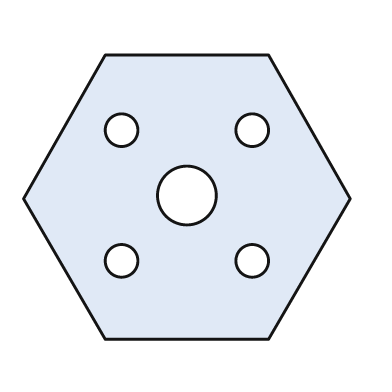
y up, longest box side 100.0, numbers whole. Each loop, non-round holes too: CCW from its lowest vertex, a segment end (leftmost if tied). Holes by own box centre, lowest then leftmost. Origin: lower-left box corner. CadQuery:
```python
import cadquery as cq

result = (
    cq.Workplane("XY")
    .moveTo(25.0, 0.0)
    .lineTo(75.0, 0.0)
    .lineTo(100.0, 43.0)
    .lineTo(75.0, 87.0)
    .lineTo(25.0, 87.0)
    .lineTo(0.0, 43.0)
    .close()
    .moveTo(30.0, 24.0)
    .circle(5.0)
    .moveTo(70.0, 24.0)
    .circle(5.0)
    .moveTo(50.0, 44.0)
    .circle(9.0)
    .moveTo(30.0, 64.0)
    .circle(5.0)
    .moveTo(70.0, 64.0)
    .circle(5.0)
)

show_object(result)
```